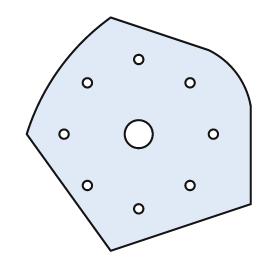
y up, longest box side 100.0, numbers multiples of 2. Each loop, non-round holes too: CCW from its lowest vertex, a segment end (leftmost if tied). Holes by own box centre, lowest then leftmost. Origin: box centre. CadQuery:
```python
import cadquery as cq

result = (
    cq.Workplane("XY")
    .moveTo(-12.0, -50.0)
    .lineTo(48.0, -30.0)
    .lineTo(48.0, 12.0)
    .threePointArc((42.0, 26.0), (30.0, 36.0))
    .lineTo(-12.0, 50.0)
    .threePointArc((-34.0, 28.0), (-48.0, 0.0))
    .close()
    .moveTo(0.0, -32.0)
    .circle(2.0)
    .moveTo(-22.0, -22.0)
    .circle(2.0)
    .moveTo(22.0, -22.0)
    .circle(2.0)
    .moveTo(-32.0, 0.0)
    .circle(2.0)
    .moveTo(0.0, 0.0)
    .circle(6.0)
    .moveTo(32.0, 0.0)
    .circle(2.0)
    .moveTo(-22.0, 22.0)
    .circle(2.0)
    .moveTo(22.0, 22.0)
    .circle(2.0)
    .moveTo(0.0, 32.0)
    .circle(2.0)
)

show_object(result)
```